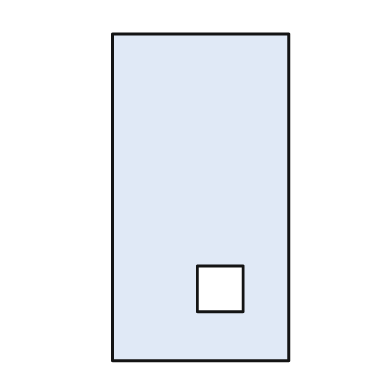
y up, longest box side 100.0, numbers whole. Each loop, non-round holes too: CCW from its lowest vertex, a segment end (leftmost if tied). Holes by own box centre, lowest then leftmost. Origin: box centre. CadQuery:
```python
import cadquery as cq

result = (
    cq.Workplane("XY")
    .moveTo(-27.0, -50.0)
    .lineTo(27.0, -50.0)
    .lineTo(27.0, 50.0)
    .lineTo(-27.0, 50.0)
    .close()
    .moveTo(-1.0, -35.0)
    .lineTo(13.0, -35.0)
    .lineTo(13.0, -21.0)
    .lineTo(-1.0, -21.0)
    .close()
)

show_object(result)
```